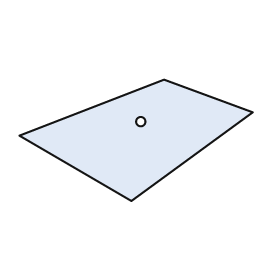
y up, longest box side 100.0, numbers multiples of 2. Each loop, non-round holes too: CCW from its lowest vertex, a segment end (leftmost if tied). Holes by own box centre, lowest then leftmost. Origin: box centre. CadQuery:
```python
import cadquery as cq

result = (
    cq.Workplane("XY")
    .moveTo(-2.0, -26.0)
    .lineTo(50.0, 12.0)
    .lineTo(12.0, 26.0)
    .lineTo(-50.0, 2.0)
    .close()
    .moveTo(2.0, 8.0)
    .circle(2.0)
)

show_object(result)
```